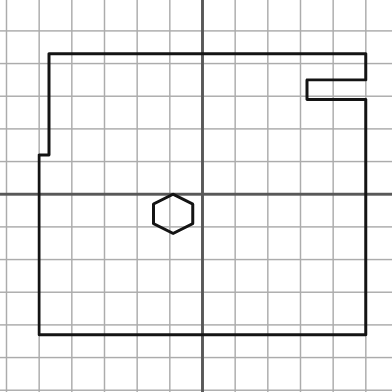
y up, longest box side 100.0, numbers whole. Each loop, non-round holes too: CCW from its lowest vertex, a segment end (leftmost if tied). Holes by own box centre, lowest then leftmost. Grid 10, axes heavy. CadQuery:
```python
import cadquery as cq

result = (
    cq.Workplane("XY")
    .moveTo(-50.0, -43.0)
    .lineTo(50.0, -43.0)
    .lineTo(50.0, 29.0)
    .lineTo(32.0, 29.0)
    .lineTo(32.0, 35.0)
    .lineTo(50.0, 35.0)
    .lineTo(50.0, 43.0)
    .lineTo(-47.0, 43.0)
    .lineTo(-47.0, 12.0)
    .lineTo(-50.0, 12.0)
    .close()
    .moveTo(-9.0, -12.0)
    .lineTo(-3.0, -9.0)
    .lineTo(-3.0, -3.0)
    .lineTo(-9.0, 0.0)
    .lineTo(-15.0, -3.0)
    .lineTo(-15.0, -9.0)
    .close()
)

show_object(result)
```